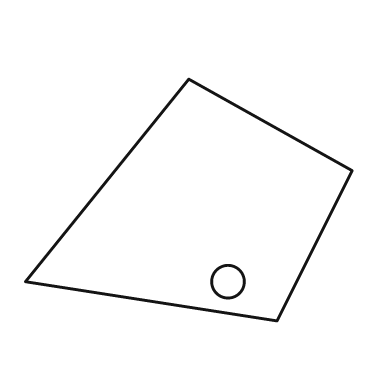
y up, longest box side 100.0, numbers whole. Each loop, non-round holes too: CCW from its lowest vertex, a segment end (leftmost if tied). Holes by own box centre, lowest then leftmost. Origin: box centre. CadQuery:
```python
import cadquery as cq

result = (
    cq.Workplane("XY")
    .moveTo(27.0, -37.0)
    .lineTo(50.0, 9.0)
    .lineTo(0.0, 37.0)
    .lineTo(-50.0, -25.0)
    .close()
    .moveTo(12.0, -25.0)
    .circle(5.0)
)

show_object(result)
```